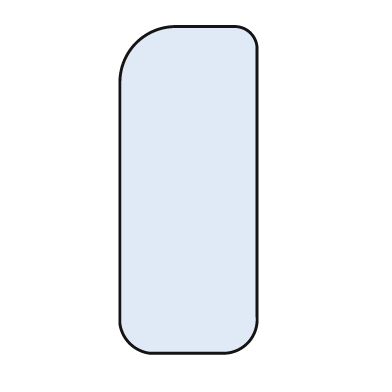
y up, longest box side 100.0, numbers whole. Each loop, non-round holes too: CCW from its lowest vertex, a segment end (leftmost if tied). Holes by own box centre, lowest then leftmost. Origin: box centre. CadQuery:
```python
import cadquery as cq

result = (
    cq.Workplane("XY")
    .moveTo(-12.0, -50.0)
    .lineTo(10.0, -50.0)
    .threePointArc((18.0, -47.0), (21.0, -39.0))
    .lineTo(21.0, 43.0)
    .threePointArc((19.0, 48.0), (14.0, 50.0))
    .lineTo(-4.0, 50.0)
    .threePointArc((-16.0, 45.0), (-21.0, 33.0))
    .lineTo(-21.0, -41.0)
    .threePointArc((-18.0, -47.0), (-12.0, -50.0))
    .close()
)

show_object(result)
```